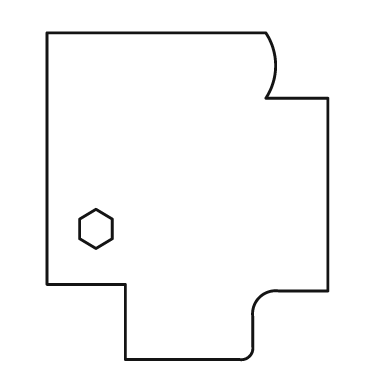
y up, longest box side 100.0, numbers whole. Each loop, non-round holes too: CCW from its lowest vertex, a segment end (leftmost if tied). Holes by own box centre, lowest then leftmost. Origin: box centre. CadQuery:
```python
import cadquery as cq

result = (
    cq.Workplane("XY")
    .moveTo(-19.0, -50.0)
    .lineTo(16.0, -50.0)
    .threePointArc((19.0, -49.0), (20.0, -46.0))
    .lineTo(20.0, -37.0)
    .threePointArc((22.0, -31.0), (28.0, -29.0))
    .lineTo(43.0, -29.0)
    .lineTo(43.0, 30.0)
    .lineTo(24.0, 30.0)
    .threePointArc((27.0, 40.0), (24.0, 50.0))
    .lineTo(-43.0, 50.0)
    .lineTo(-43.0, -27.0)
    .lineTo(-19.0, -27.0)
    .close()
    .moveTo(-28.0, -16.0)
    .lineTo(-23.0, -13.0)
    .lineTo(-23.0, -7.0)
    .lineTo(-28.0, -4.0)
    .lineTo(-33.0, -7.0)
    .lineTo(-33.0, -13.0)
    .close()
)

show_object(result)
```